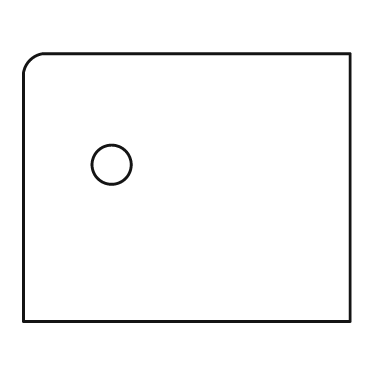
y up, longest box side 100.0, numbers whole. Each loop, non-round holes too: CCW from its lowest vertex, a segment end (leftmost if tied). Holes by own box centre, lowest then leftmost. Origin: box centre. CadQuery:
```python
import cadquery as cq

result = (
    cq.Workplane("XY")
    .moveTo(-50.0, -41.0)
    .lineTo(50.0, -41.0)
    .lineTo(50.0, 41.0)
    .lineTo(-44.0, 41.0)
    .threePointArc((-48.0, 39.0), (-50.0, 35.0))
    .close()
    .moveTo(-23.0, 7.0)
    .circle(6.0)
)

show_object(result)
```